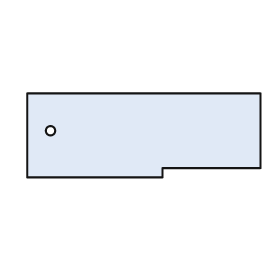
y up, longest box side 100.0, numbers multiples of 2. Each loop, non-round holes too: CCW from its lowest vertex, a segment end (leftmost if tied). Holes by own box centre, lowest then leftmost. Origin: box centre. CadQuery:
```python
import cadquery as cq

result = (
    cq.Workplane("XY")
    .moveTo(-50.0, -18.0)
    .lineTo(8.0, -18.0)
    .lineTo(8.0, -14.0)
    .lineTo(50.0, -14.0)
    .lineTo(50.0, 18.0)
    .lineTo(-50.0, 18.0)
    .close()
    .moveTo(-40.0, 2.0)
    .circle(2.0)
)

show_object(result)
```